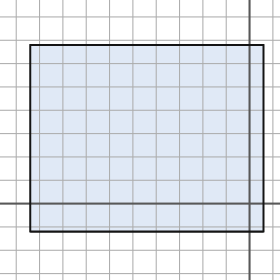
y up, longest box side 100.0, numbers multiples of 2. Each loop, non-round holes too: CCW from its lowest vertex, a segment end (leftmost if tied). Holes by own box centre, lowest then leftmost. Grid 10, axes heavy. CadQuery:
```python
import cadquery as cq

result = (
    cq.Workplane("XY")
    .moveTo(-94.0, -12.0)
    .lineTo(6.0, -12.0)
    .lineTo(6.0, 68.0)
    .lineTo(-94.0, 68.0)
    .close()
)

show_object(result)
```